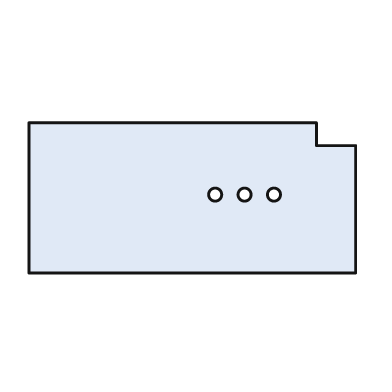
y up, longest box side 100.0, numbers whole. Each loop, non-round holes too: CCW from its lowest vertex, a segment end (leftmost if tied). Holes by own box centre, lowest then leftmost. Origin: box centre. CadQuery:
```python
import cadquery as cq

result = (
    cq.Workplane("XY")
    .moveTo(-50.0, -23.0)
    .lineTo(50.0, -23.0)
    .lineTo(50.0, 16.0)
    .lineTo(38.0, 16.0)
    .lineTo(38.0, 23.0)
    .lineTo(-50.0, 23.0)
    .close()
    .moveTo(7.0, 1.0)
    .circle(2.0)
    .moveTo(16.0, 1.0)
    .circle(2.0)
    .moveTo(25.0, 1.0)
    .circle(2.0)
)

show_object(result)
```